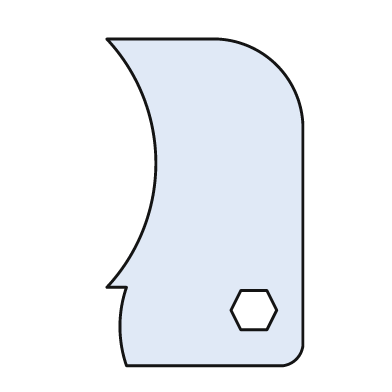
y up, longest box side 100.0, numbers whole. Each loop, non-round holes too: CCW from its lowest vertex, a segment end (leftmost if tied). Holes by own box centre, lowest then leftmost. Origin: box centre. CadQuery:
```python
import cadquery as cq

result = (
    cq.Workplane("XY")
    .moveTo(-24.0, -50.0)
    .lineTo(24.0, -50.0)
    .threePointArc((28.0, -48.0), (30.0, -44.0))
    .lineTo(30.0, 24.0)
    .threePointArc((22.0, 42.0), (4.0, 50.0))
    .lineTo(-30.0, 50.0)
    .threePointArc((-15.0, 12.0), (-30.0, -26.0))
    .lineTo(-24.0, -26.0)
    .threePointArc((-26.0, -38.0), (-24.0, -50.0))
    .close()
    .moveTo(11.0, -39.0)
    .lineTo(19.0, -39.0)
    .lineTo(22.0, -33.0)
    .lineTo(19.0, -27.0)
    .lineTo(11.0, -27.0)
    .lineTo(8.0, -33.0)
    .close()
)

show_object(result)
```